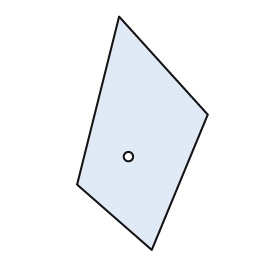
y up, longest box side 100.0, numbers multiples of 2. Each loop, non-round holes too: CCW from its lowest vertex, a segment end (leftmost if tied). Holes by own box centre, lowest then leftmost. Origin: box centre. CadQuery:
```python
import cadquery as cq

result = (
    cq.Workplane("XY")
    .moveTo(4.0, -50.0)
    .lineTo(28.0, 8.0)
    .lineTo(-10.0, 50.0)
    .lineTo(-28.0, -22.0)
    .close()
    .moveTo(-6.0, -10.0)
    .circle(2.0)
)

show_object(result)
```